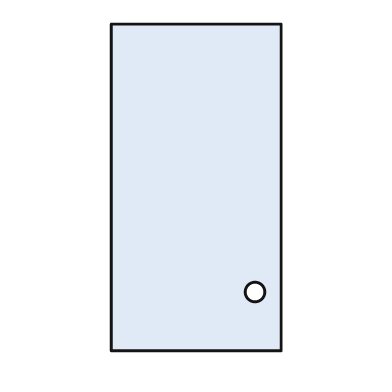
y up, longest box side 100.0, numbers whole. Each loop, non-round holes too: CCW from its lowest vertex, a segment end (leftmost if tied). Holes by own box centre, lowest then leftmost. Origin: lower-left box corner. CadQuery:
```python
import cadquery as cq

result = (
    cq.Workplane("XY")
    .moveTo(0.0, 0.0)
    .lineTo(52.0, 0.0)
    .lineTo(52.0, 100.0)
    .lineTo(0.0, 100.0)
    .close()
    .moveTo(44.0, 18.0)
    .circle(3.0)
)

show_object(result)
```